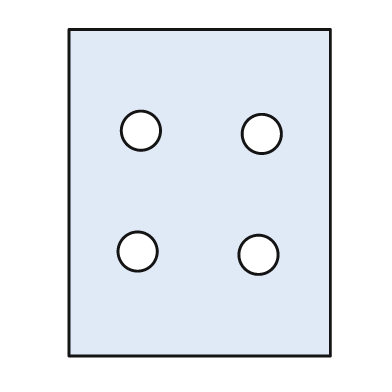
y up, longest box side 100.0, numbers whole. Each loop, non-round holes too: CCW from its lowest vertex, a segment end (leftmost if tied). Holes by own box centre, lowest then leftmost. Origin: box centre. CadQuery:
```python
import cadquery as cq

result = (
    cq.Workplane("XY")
    .moveTo(-40.0, -50.0)
    .lineTo(40.0, -50.0)
    .lineTo(40.0, 50.0)
    .lineTo(-40.0, 50.0)
    .close()
    .moveTo(18.0, -19.0)
    .circle(6.0)
    .moveTo(-19.0, -18.0)
    .circle(6.0)
    .moveTo(19.0, 18.0)
    .circle(6.0)
    .moveTo(-18.0, 19.0)
    .circle(6.0)
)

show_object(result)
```